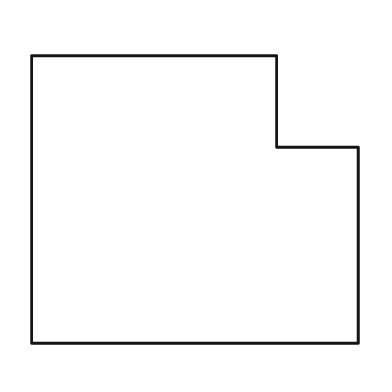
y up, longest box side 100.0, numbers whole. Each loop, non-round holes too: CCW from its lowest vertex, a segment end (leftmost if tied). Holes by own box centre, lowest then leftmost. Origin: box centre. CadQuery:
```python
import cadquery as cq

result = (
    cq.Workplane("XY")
    .moveTo(-50.0, -44.0)
    .lineTo(50.0, -44.0)
    .lineTo(50.0, 16.0)
    .lineTo(25.0, 16.0)
    .lineTo(25.0, 44.0)
    .lineTo(-50.0, 44.0)
    .close()
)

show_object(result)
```